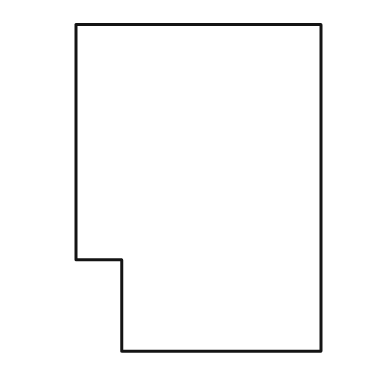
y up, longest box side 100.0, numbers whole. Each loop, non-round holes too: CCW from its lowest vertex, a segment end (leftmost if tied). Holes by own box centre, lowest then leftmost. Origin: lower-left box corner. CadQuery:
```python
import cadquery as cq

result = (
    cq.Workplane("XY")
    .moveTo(14.0, 0.0)
    .lineTo(75.0, 0.0)
    .lineTo(75.0, 100.0)
    .lineTo(0.0, 100.0)
    .lineTo(0.0, 28.0)
    .lineTo(14.0, 28.0)
    .close()
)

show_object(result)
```